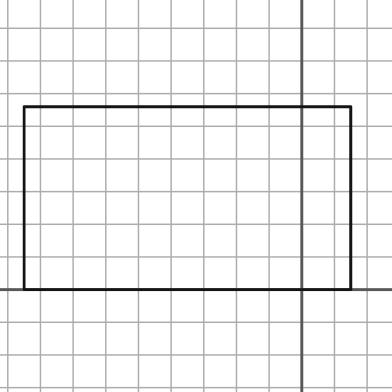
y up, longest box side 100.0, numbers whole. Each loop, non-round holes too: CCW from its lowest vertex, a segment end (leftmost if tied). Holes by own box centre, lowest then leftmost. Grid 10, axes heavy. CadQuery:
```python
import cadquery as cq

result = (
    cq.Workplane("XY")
    .moveTo(-85.0, 0.0)
    .lineTo(15.0, 0.0)
    .lineTo(15.0, 56.0)
    .lineTo(-85.0, 56.0)
    .close()
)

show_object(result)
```